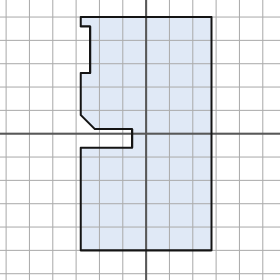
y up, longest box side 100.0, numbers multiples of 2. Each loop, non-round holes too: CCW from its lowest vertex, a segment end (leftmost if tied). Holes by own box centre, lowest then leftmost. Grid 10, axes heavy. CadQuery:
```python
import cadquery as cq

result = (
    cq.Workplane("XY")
    .moveTo(-28.0, -50.0)
    .lineTo(28.0, -50.0)
    .lineTo(28.0, 50.0)
    .lineTo(-28.0, 50.0)
    .lineTo(-28.0, 46.0)
    .lineTo(-24.0, 46.0)
    .lineTo(-24.0, 26.0)
    .lineTo(-28.0, 26.0)
    .lineTo(-28.0, 8.0)
    .lineTo(-22.0, 2.0)
    .lineTo(-6.0, 2.0)
    .lineTo(-6.0, -6.0)
    .lineTo(-28.0, -6.0)
    .close()
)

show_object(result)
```